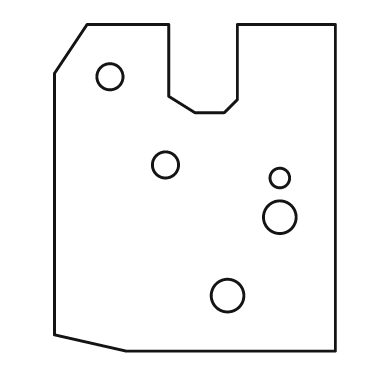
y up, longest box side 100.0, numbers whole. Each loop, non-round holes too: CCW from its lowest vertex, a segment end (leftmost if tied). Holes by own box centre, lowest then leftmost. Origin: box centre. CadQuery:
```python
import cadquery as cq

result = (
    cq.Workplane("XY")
    .moveTo(-21.0, -50.0)
    .lineTo(43.0, -50.0)
    .lineTo(43.0, 50.0)
    .lineTo(13.0, 50.0)
    .lineTo(13.0, 27.0)
    .lineTo(9.0, 23.0)
    .lineTo(0.0, 23.0)
    .lineTo(-8.0, 28.0)
    .lineTo(-8.0, 50.0)
    .lineTo(-33.0, 50.0)
    .lineTo(-43.0, 35.0)
    .lineTo(-43.0, -45.0)
    .close()
    .moveTo(10.0, -33.0)
    .circle(5.0)
    .moveTo(26.0, -9.0)
    .circle(5.0)
    .moveTo(26.0, 3.0)
    .circle(3.0)
    .moveTo(-9.0, 7.0)
    .circle(4.0)
    .moveTo(-26.0, 34.0)
    .circle(4.0)
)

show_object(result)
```